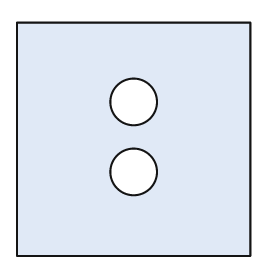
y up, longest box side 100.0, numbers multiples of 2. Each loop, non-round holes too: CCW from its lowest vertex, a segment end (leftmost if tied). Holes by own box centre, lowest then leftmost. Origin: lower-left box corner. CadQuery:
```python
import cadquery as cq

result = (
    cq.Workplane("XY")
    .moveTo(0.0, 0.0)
    .lineTo(100.0, 0.0)
    .lineTo(100.0, 100.0)
    .lineTo(0.0, 100.0)
    .close()
    .moveTo(50.0, 36.0)
    .circle(10.0)
    .moveTo(50.0, 66.0)
    .circle(10.0)
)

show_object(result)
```